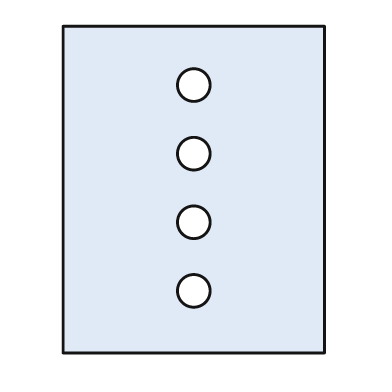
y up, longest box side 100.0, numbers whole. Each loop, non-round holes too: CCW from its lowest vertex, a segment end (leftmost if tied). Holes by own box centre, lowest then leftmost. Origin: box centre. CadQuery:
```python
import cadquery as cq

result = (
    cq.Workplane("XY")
    .moveTo(-40.0, -50.0)
    .lineTo(40.0, -50.0)
    .lineTo(40.0, 50.0)
    .lineTo(-40.0, 50.0)
    .close()
    .moveTo(0.0, -31.0)
    .circle(5.0)
    .moveTo(0.0, -10.0)
    .circle(5.0)
    .moveTo(0.0, 11.0)
    .circle(5.0)
    .moveTo(0.0, 32.0)
    .circle(5.0)
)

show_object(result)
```